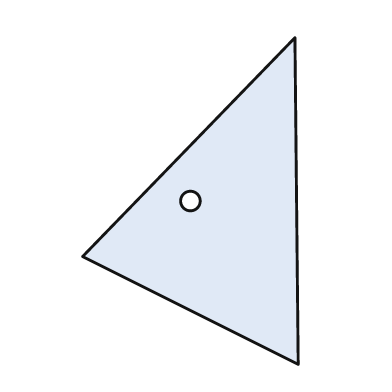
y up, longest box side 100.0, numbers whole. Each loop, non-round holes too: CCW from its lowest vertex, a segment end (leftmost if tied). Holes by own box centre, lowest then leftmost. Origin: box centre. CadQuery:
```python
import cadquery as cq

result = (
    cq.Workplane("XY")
    .moveTo(33.0, -50.0)
    .lineTo(32.0, 50.0)
    .lineTo(-33.0, -17.0)
    .close()
    .moveTo(0.0, 0.0)
    .circle(3.0)
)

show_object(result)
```